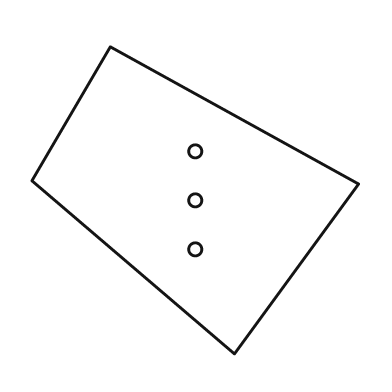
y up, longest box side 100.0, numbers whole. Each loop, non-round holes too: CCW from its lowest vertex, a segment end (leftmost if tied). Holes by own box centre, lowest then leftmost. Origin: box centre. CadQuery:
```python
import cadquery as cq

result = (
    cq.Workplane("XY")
    .moveTo(12.0, -47.0)
    .lineTo(50.0, 5.0)
    .lineTo(-26.0, 47.0)
    .lineTo(-50.0, 6.0)
    .close()
    .moveTo(0.0, -15.0)
    .circle(2.0)
    .moveTo(0.0, 0.0)
    .circle(2.0)
    .moveTo(0.0, 15.0)
    .circle(2.0)
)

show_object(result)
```